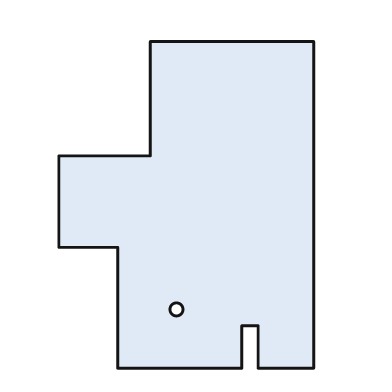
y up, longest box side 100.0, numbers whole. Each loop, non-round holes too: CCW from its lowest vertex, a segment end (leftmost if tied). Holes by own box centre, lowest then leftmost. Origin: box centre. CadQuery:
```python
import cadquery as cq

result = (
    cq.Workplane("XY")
    .moveTo(-21.0, -50.0)
    .lineTo(17.0, -50.0)
    .lineTo(17.0, -37.0)
    .lineTo(22.0, -37.0)
    .lineTo(22.0, -50.0)
    .lineTo(39.0, -50.0)
    .lineTo(39.0, 50.0)
    .lineTo(-11.0, 50.0)
    .lineTo(-11.0, 15.0)
    .lineTo(-39.0, 15.0)
    .lineTo(-39.0, -13.0)
    .lineTo(-21.0, -13.0)
    .close()
    .moveTo(-3.0, -32.0)
    .circle(2.0)
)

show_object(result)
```